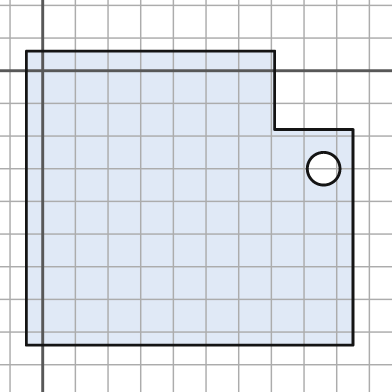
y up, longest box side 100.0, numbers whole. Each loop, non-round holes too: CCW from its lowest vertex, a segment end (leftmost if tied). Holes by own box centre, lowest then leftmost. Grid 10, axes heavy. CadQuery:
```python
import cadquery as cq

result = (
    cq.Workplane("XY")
    .moveTo(-5.0, -84.0)
    .lineTo(95.0, -84.0)
    .lineTo(95.0, -18.0)
    .lineTo(71.0, -18.0)
    .lineTo(71.0, 6.0)
    .lineTo(-5.0, 6.0)
    .close()
    .moveTo(86.0, -30.0)
    .circle(5.0)
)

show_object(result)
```